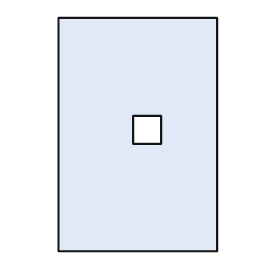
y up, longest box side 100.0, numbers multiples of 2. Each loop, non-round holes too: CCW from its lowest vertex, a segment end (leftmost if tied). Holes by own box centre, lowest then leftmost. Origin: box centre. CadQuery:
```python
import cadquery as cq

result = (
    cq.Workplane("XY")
    .moveTo(-34.0, -50.0)
    .lineTo(34.0, -50.0)
    .lineTo(34.0, 50.0)
    .lineTo(-34.0, 50.0)
    .close()
    .moveTo(-2.0, -4.0)
    .lineTo(10.0, -4.0)
    .lineTo(10.0, 8.0)
    .lineTo(-2.0, 8.0)
    .close()
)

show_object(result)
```